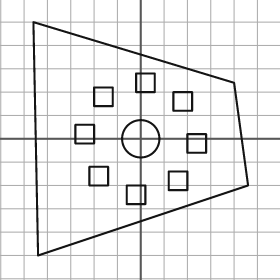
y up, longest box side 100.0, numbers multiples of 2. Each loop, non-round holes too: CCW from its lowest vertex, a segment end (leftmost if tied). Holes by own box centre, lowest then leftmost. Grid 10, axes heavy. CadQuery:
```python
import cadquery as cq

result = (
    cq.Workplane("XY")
    .moveTo(-44.0, -50.0)
    .lineTo(46.0, -20.0)
    .lineTo(40.0, 24.0)
    .lineTo(-46.0, 50.0)
    .close()
    .moveTo(-6.0, -28.0)
    .lineTo(2.0, -28.0)
    .lineTo(2.0, -20.0)
    .lineTo(-6.0, -20.0)
    .close()
    .moveTo(12.0, -22.0)
    .lineTo(20.0, -22.0)
    .lineTo(20.0, -14.0)
    .lineTo(12.0, -14.0)
    .close()
    .moveTo(-22.0, -20.0)
    .lineTo(-14.0, -20.0)
    .lineTo(-14.0, -12.0)
    .lineTo(-22.0, -12.0)
    .close()
    .moveTo(20.0, -6.0)
    .lineTo(28.0, -6.0)
    .lineTo(28.0, 2.0)
    .lineTo(20.0, 2.0)
    .close()
    .moveTo(0.0, 0.0)
    .circle(8.0)
    .moveTo(-28.0, -2.0)
    .lineTo(-20.0, -2.0)
    .lineTo(-20.0, 6.0)
    .lineTo(-28.0, 6.0)
    .close()
    .moveTo(14.0, 12.0)
    .lineTo(22.0, 12.0)
    .lineTo(22.0, 20.0)
    .lineTo(14.0, 20.0)
    .close()
    .moveTo(-20.0, 14.0)
    .lineTo(-12.0, 14.0)
    .lineTo(-12.0, 22.0)
    .lineTo(-20.0, 22.0)
    .close()
    .moveTo(-2.0, 20.0)
    .lineTo(6.0, 20.0)
    .lineTo(6.0, 28.0)
    .lineTo(-2.0, 28.0)
    .close()
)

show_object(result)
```